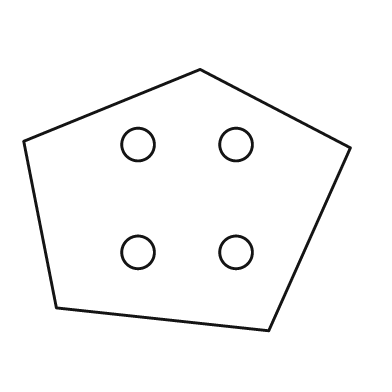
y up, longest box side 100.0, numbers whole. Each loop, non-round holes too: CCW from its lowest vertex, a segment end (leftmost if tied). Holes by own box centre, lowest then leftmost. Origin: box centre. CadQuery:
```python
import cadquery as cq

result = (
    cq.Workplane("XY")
    .moveTo(25.0, -40.0)
    .lineTo(50.0, 16.0)
    .lineTo(4.0, 40.0)
    .lineTo(-50.0, 18.0)
    .lineTo(-40.0, -33.0)
    .close()
    .moveTo(-15.0, -16.0)
    .circle(5.0)
    .moveTo(15.0, -16.0)
    .circle(5.0)
    .moveTo(-15.0, 17.0)
    .circle(5.0)
    .moveTo(15.0, 17.0)
    .circle(5.0)
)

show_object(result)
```